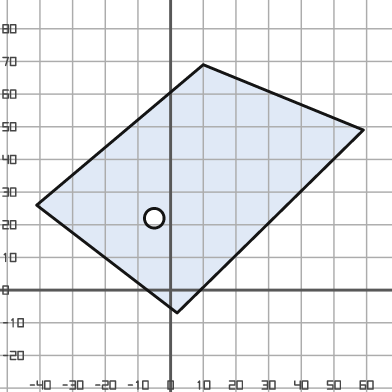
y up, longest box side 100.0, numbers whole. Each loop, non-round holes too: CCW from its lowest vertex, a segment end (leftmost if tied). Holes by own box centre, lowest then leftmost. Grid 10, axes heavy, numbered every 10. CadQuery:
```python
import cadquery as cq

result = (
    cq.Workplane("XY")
    .moveTo(2.0, -7.0)
    .lineTo(59.0, 49.0)
    .lineTo(10.0, 69.0)
    .lineTo(-41.0, 26.0)
    .close()
    .moveTo(-5.0, 22.0)
    .circle(3.0)
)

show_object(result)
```